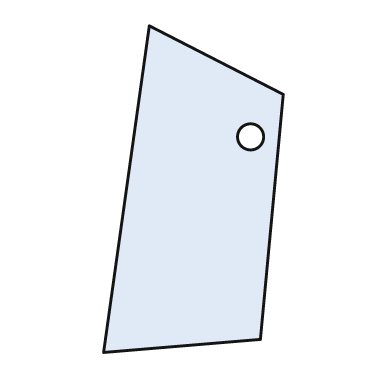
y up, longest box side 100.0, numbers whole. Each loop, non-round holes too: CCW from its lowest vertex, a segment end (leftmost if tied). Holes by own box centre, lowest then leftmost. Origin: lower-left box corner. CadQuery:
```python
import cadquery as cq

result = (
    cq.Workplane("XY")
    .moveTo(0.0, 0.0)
    .lineTo(48.0, 4.0)
    .lineTo(55.0, 79.0)
    .lineTo(14.0, 100.0)
    .close()
    .moveTo(45.0, 66.0)
    .circle(4.0)
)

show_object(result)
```